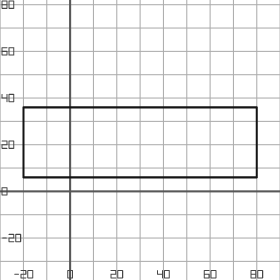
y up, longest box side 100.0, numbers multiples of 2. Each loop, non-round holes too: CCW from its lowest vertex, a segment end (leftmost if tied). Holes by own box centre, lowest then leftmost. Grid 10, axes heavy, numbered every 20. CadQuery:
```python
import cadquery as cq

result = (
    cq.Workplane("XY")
    .moveTo(-20.0, 6.0)
    .lineTo(80.0, 6.0)
    .lineTo(80.0, 36.0)
    .lineTo(-20.0, 36.0)
    .close()
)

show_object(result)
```